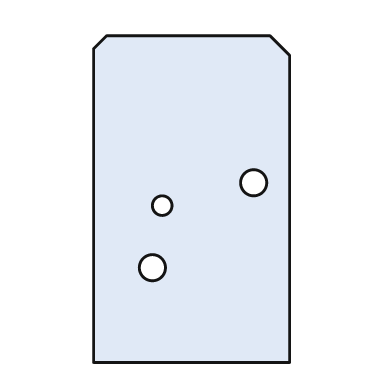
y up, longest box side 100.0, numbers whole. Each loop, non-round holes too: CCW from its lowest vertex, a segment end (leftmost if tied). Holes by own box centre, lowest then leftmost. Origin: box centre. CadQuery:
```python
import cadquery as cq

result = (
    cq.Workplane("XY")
    .moveTo(-30.0, -50.0)
    .lineTo(30.0, -50.0)
    .lineTo(30.0, 44.0)
    .lineTo(24.0, 50.0)
    .lineTo(-26.0, 50.0)
    .lineTo(-30.0, 46.0)
    .close()
    .moveTo(-12.0, -21.0)
    .circle(4.0)
    .moveTo(-9.0, -2.0)
    .circle(3.0)
    .moveTo(19.0, 5.0)
    .circle(4.0)
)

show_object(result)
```